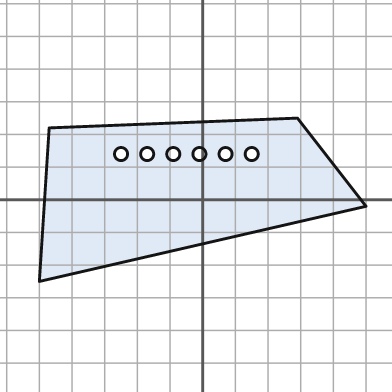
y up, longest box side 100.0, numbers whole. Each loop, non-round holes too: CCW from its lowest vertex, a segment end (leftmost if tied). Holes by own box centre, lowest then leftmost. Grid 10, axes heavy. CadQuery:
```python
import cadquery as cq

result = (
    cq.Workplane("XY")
    .moveTo(-50.0, -25.0)
    .lineTo(50.0, -2.0)
    .lineTo(29.0, 25.0)
    .lineTo(-47.0, 22.0)
    .close()
    .moveTo(-25.0, 14.0)
    .circle(2.0)
    .moveTo(-17.0, 14.0)
    .circle(2.0)
    .moveTo(-9.0, 14.0)
    .circle(2.0)
    .moveTo(-1.0, 14.0)
    .circle(2.0)
    .moveTo(7.0, 14.0)
    .circle(2.0)
    .moveTo(15.0, 14.0)
    .circle(2.0)
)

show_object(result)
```